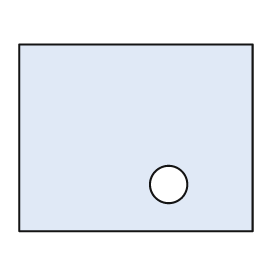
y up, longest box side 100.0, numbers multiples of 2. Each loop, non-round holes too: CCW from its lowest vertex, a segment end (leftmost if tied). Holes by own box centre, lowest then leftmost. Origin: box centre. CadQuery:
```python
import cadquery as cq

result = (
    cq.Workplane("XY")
    .moveTo(-50.0, -40.0)
    .lineTo(50.0, -40.0)
    .lineTo(50.0, 40.0)
    .lineTo(-50.0, 40.0)
    .close()
    .moveTo(14.0, -20.0)
    .circle(8.0)
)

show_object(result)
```